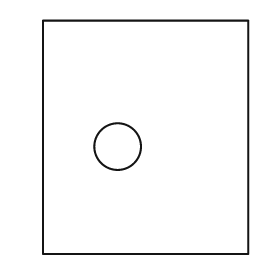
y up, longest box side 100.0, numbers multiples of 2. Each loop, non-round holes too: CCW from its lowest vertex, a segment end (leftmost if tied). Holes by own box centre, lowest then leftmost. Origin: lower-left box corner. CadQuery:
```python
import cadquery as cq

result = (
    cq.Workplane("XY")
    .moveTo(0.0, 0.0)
    .lineTo(88.0, 0.0)
    .lineTo(88.0, 100.0)
    .lineTo(0.0, 100.0)
    .close()
    .moveTo(32.0, 46.0)
    .circle(10.0)
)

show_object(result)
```